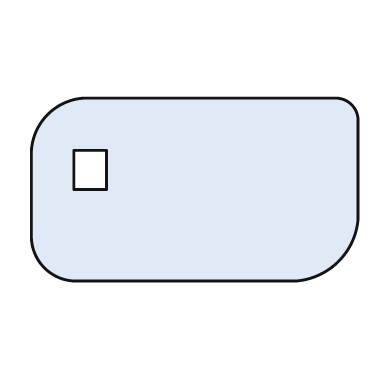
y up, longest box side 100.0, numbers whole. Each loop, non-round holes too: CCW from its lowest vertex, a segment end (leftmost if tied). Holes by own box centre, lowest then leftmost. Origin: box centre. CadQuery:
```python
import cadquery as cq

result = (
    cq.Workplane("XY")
    .moveTo(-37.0, -28.0)
    .lineTo(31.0, -28.0)
    .threePointArc((44.0, -22.0), (50.0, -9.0))
    .lineTo(50.0, 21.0)
    .threePointArc((48.0, 26.0), (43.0, 28.0))
    .lineTo(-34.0, 28.0)
    .threePointArc((-45.0, 23.0), (-50.0, 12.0))
    .lineTo(-50.0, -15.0)
    .threePointArc((-46.0, -24.0), (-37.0, -28.0))
    .close()
    .moveTo(-37.0, 0.0)
    .lineTo(-27.0, 0.0)
    .lineTo(-27.0, 12.0)
    .lineTo(-37.0, 12.0)
    .close()
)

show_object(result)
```